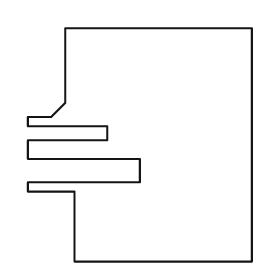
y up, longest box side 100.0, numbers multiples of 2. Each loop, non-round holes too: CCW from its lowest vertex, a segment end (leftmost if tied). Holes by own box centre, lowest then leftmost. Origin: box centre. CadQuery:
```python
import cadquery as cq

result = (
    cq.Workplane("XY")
    .moveTo(-28.0, -50.0)
    .lineTo(48.0, -50.0)
    .lineTo(48.0, 50.0)
    .lineTo(-32.0, 50.0)
    .lineTo(-32.0, 18.0)
    .lineTo(-38.0, 12.0)
    .lineTo(-48.0, 12.0)
    .lineTo(-48.0, 8.0)
    .lineTo(-14.0, 8.0)
    .lineTo(-14.0, 2.0)
    .lineTo(-48.0, 2.0)
    .lineTo(-48.0, -6.0)
    .lineTo(0.0, -6.0)
    .lineTo(0.0, -16.0)
    .lineTo(-48.0, -16.0)
    .lineTo(-48.0, -20.0)
    .lineTo(-28.0, -20.0)
    .close()
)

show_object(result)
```